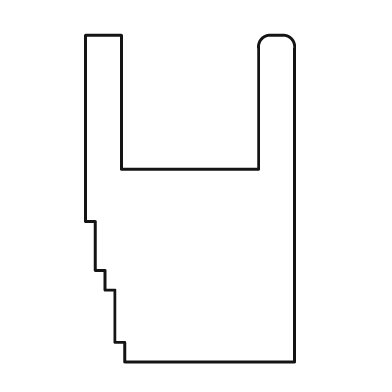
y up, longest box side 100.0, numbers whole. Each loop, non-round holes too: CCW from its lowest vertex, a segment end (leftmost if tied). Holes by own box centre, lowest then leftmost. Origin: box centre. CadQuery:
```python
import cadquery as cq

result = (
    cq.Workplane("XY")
    .moveTo(-20.0, -50.0)
    .lineTo(32.0, -50.0)
    .lineTo(32.0, 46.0)
    .threePointArc((31.0, 49.0), (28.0, 50.0))
    .lineTo(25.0, 50.0)
    .threePointArc((22.0, 49.0), (21.0, 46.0))
    .lineTo(21.0, 9.0)
    .lineTo(-21.0, 9.0)
    .lineTo(-21.0, 50.0)
    .lineTo(-32.0, 50.0)
    .lineTo(-32.0, -7.0)
    .lineTo(-29.0, -7.0)
    .lineTo(-29.0, -22.0)
    .lineTo(-26.0, -22.0)
    .lineTo(-26.0, -28.0)
    .lineTo(-23.0, -28.0)
    .lineTo(-23.0, -44.0)
    .lineTo(-20.0, -44.0)
    .close()
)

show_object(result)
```